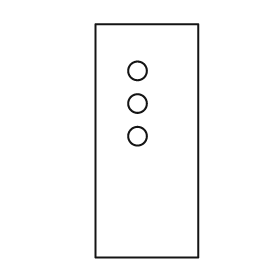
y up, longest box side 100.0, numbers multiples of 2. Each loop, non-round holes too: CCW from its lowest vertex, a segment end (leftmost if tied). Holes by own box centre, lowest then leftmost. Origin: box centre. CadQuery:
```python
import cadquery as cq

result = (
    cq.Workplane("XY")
    .moveTo(-22.0, -50.0)
    .lineTo(22.0, -50.0)
    .lineTo(22.0, 50.0)
    .lineTo(-22.0, 50.0)
    .close()
    .moveTo(-4.0, 2.0)
    .circle(4.0)
    .moveTo(-4.0, 16.0)
    .circle(4.0)
    .moveTo(-4.0, 30.0)
    .circle(4.0)
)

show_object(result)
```